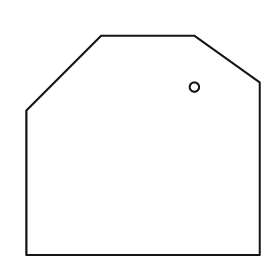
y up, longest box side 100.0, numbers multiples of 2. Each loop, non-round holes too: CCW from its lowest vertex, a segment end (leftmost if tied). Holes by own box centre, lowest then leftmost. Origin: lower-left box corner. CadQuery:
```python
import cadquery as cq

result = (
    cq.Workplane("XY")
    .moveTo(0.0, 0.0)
    .lineTo(100.0, 0.0)
    .lineTo(100.0, 74.0)
    .lineTo(72.0, 94.0)
    .lineTo(32.0, 94.0)
    .lineTo(0.0, 62.0)
    .close()
    .moveTo(72.0, 72.0)
    .circle(2.0)
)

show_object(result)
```